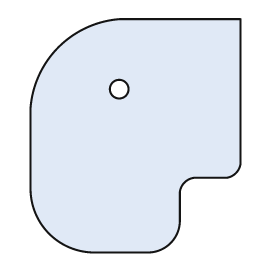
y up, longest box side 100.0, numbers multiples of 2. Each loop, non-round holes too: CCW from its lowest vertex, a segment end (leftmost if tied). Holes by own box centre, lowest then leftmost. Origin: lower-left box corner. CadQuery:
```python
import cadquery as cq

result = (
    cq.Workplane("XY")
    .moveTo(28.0, 0.0)
    .lineTo(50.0, 0.0)
    .threePointArc((60.0, 4.0), (64.0, 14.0))
    .lineTo(64.0, 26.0)
    .threePointArc((66.0, 30.0), (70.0, 32.0))
    .lineTo(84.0, 32.0)
    .threePointArc((88.0, 34.0), (90.0, 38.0))
    .lineTo(90.0, 100.0)
    .lineTo(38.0, 100.0)
    .threePointArc((12.0, 88.0), (0.0, 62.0))
    .lineTo(0.0, 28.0)
    .threePointArc((8.0, 8.0), (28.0, 0.0))
    .close()
    .moveTo(38.0, 70.0)
    .circle(4.0)
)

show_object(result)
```